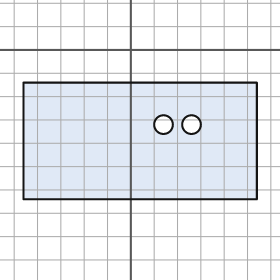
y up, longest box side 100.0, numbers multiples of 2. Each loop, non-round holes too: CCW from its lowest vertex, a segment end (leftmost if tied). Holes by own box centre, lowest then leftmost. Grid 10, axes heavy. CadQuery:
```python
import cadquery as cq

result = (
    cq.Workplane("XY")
    .moveTo(-46.0, -64.0)
    .lineTo(54.0, -64.0)
    .lineTo(54.0, -14.0)
    .lineTo(-46.0, -14.0)
    .close()
    .moveTo(14.0, -32.0)
    .circle(4.0)
    .moveTo(26.0, -32.0)
    .circle(4.0)
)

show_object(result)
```